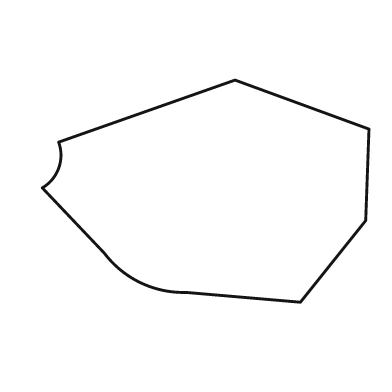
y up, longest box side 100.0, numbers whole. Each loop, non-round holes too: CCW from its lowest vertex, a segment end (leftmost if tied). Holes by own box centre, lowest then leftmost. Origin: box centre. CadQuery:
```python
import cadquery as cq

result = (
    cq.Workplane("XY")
    .moveTo(29.0, -34.0)
    .lineTo(49.0, -9.0)
    .lineTo(50.0, 19.0)
    .lineTo(9.0, 34.0)
    .lineTo(-45.0, 15.0)
    .threePointArc((-45.0, 7.0), (-50.0, 1.0))
    .lineTo(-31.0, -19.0)
    .threePointArc((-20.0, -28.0), (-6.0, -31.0))
    .close()
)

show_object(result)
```